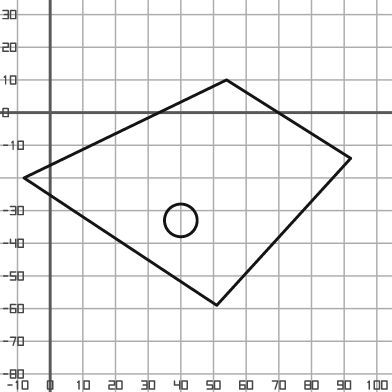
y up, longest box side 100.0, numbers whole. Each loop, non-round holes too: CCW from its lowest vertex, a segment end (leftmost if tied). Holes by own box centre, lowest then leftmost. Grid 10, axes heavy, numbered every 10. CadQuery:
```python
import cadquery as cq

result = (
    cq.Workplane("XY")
    .moveTo(51.0, -59.0)
    .lineTo(92.0, -14.0)
    .lineTo(54.0, 10.0)
    .lineTo(-8.0, -20.0)
    .close()
    .moveTo(40.0, -33.0)
    .circle(5.0)
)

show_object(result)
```